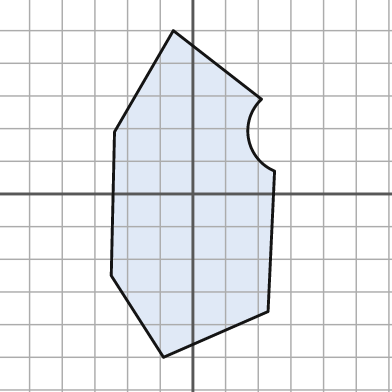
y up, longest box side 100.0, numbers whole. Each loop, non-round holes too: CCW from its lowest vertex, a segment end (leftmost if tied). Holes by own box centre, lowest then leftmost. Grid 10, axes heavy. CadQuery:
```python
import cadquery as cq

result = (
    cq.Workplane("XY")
    .moveTo(-9.0, -50.0)
    .lineTo(23.0, -36.0)
    .lineTo(25.0, 7.0)
    .threePointArc((17.0, 17.0), (21.0, 29.0))
    .lineTo(-6.0, 50.0)
    .lineTo(-24.0, 19.0)
    .lineTo(-25.0, -25.0)
    .close()
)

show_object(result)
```